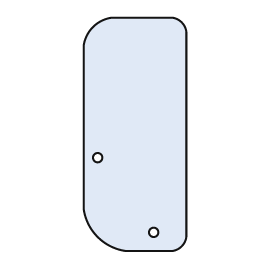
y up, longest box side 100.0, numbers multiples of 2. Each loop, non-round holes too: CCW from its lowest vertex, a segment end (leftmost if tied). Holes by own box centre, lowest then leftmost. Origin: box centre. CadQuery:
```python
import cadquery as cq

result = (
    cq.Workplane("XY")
    .moveTo(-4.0, -50.0)
    .lineTo(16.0, -50.0)
    .threePointArc((20.0, -48.0), (22.0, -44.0))
    .lineTo(22.0, 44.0)
    .threePointArc((20.0, 48.0), (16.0, 50.0))
    .lineTo(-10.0, 50.0)
    .threePointArc((-18.0, 46.0), (-22.0, 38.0))
    .lineTo(-22.0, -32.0)
    .threePointArc((-16.0, -44.0), (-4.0, -50.0))
    .close()
    .moveTo(8.0, -42.0)
    .circle(2.0)
    .moveTo(-16.0, -10.0)
    .circle(2.0)
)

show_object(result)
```